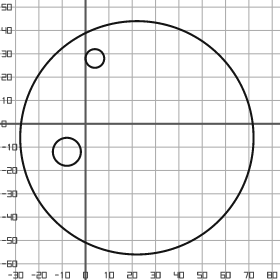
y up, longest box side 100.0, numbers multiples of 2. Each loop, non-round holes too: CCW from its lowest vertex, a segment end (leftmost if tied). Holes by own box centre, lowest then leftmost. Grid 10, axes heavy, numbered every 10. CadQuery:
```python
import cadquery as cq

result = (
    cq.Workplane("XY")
    .moveTo(22.0, -6.0)
    .circle(50.0)
    .moveTo(-8.0, -12.0)
    .circle(6.0)
    .moveTo(4.0, 28.0)
    .circle(4.0)
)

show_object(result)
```